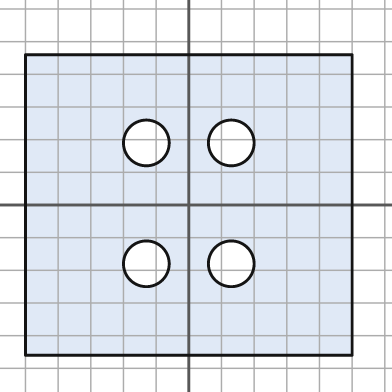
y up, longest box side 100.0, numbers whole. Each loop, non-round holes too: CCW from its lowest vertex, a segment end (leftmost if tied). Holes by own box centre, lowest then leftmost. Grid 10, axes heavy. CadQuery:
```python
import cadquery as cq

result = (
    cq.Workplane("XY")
    .moveTo(-50.0, -46.0)
    .lineTo(50.0, -46.0)
    .lineTo(50.0, 46.0)
    .lineTo(-50.0, 46.0)
    .close()
    .moveTo(-13.0, -18.0)
    .circle(7.0)
    .moveTo(13.0, -18.0)
    .circle(7.0)
    .moveTo(-13.0, 19.0)
    .circle(7.0)
    .moveTo(13.0, 19.0)
    .circle(7.0)
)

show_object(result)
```